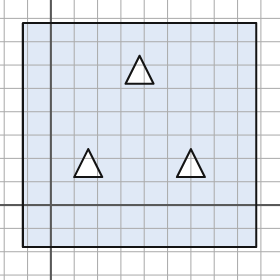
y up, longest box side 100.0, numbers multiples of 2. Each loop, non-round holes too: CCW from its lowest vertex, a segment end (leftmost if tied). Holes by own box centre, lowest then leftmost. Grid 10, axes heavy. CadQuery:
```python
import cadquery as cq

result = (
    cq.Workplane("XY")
    .moveTo(-12.0, -18.0)
    .lineTo(88.0, -18.0)
    .lineTo(88.0, 78.0)
    .lineTo(-12.0, 78.0)
    .close()
    .moveTo(10.0, 12.0)
    .lineTo(22.0, 12.0)
    .lineTo(16.0, 24.0)
    .close()
    .moveTo(54.0, 12.0)
    .lineTo(66.0, 12.0)
    .lineTo(60.0, 24.0)
    .close()
    .moveTo(32.0, 52.0)
    .lineTo(44.0, 52.0)
    .lineTo(38.0, 64.0)
    .close()
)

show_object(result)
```